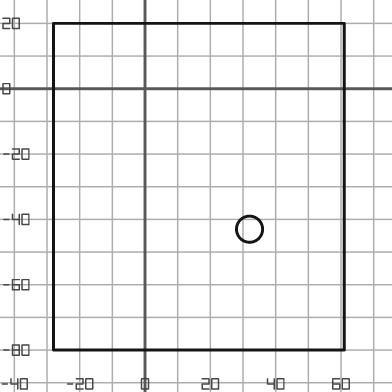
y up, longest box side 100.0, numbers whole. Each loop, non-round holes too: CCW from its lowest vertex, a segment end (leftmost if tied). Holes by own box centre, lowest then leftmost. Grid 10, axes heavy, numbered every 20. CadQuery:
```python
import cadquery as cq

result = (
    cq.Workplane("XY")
    .moveTo(-28.0, -80.0)
    .lineTo(61.0, -80.0)
    .lineTo(61.0, 20.0)
    .lineTo(-28.0, 20.0)
    .close()
    .moveTo(32.0, -43.0)
    .circle(4.0)
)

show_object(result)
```